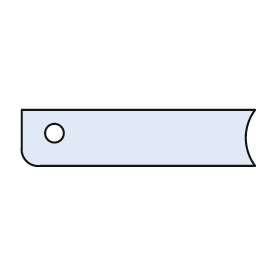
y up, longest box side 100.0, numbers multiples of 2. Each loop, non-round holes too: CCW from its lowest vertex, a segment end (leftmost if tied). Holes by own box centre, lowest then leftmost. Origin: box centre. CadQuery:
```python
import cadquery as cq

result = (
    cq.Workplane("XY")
    .moveTo(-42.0, -12.0)
    .lineTo(50.0, -12.0)
    .threePointArc((46.0, 0.0), (50.0, 12.0))
    .lineTo(-50.0, 12.0)
    .lineTo(-50.0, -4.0)
    .threePointArc((-48.0, -10.0), (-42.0, -12.0))
    .close()
    .moveTo(-36.0, 2.0)
    .circle(4.0)
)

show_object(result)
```